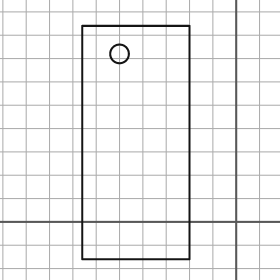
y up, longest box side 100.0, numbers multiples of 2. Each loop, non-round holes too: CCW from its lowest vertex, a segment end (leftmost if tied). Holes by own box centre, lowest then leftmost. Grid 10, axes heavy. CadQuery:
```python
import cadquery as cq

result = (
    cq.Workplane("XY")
    .moveTo(-66.0, -16.0)
    .lineTo(-20.0, -16.0)
    .lineTo(-20.0, 84.0)
    .lineTo(-66.0, 84.0)
    .close()
    .moveTo(-50.0, 72.0)
    .circle(4.0)
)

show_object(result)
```